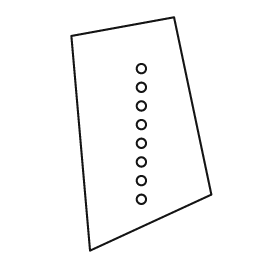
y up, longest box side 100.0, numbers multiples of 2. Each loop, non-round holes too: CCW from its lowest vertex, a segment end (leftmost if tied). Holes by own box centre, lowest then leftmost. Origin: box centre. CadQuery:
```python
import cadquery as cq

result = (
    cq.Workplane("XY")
    .moveTo(-22.0, -50.0)
    .lineTo(30.0, -26.0)
    .lineTo(14.0, 50.0)
    .lineTo(-30.0, 42.0)
    .close()
    .moveTo(0.0, -28.0)
    .circle(2.0)
    .moveTo(0.0, -20.0)
    .circle(2.0)
    .moveTo(0.0, -12.0)
    .circle(2.0)
    .moveTo(0.0, -4.0)
    .circle(2.0)
    .moveTo(0.0, 4.0)
    .circle(2.0)
    .moveTo(0.0, 12.0)
    .circle(2.0)
    .moveTo(0.0, 20.0)
    .circle(2.0)
    .moveTo(0.0, 28.0)
    .circle(2.0)
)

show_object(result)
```